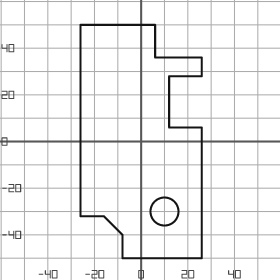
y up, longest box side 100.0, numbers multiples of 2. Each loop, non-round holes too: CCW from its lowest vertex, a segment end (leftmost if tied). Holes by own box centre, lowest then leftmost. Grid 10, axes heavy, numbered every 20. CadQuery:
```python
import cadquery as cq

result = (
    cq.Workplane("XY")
    .moveTo(-8.0, -50.0)
    .lineTo(26.0, -50.0)
    .lineTo(26.0, 6.0)
    .lineTo(12.0, 6.0)
    .lineTo(12.0, 28.0)
    .lineTo(26.0, 28.0)
    .lineTo(26.0, 36.0)
    .lineTo(6.0, 36.0)
    .lineTo(6.0, 50.0)
    .lineTo(-26.0, 50.0)
    .lineTo(-26.0, -32.0)
    .lineTo(-16.0, -32.0)
    .lineTo(-8.0, -40.0)
    .close()
    .moveTo(10.0, -30.0)
    .circle(6.0)
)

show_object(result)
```